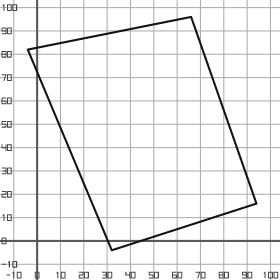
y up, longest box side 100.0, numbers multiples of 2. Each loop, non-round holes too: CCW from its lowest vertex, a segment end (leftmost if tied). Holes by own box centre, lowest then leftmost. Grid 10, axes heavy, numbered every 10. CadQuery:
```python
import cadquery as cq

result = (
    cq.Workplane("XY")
    .moveTo(32.0, -4.0)
    .lineTo(94.0, 16.0)
    .lineTo(66.0, 96.0)
    .lineTo(-4.0, 82.0)
    .close()
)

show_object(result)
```